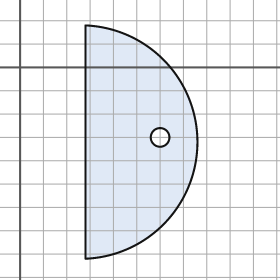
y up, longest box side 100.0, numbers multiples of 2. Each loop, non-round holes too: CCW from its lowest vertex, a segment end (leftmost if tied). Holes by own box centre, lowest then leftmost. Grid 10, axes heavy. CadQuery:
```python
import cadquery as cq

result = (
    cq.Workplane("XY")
    .moveTo(28.0, -82.0)
    .threePointArc((76.0, -32.0), (28.0, 18.0))
    .close()
    .moveTo(60.0, -30.0)
    .circle(4.0)
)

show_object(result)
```